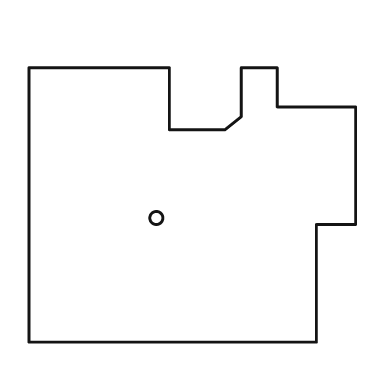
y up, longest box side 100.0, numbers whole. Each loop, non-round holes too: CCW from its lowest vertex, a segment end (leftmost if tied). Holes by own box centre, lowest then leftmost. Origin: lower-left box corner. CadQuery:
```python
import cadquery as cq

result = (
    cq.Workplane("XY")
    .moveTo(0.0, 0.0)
    .lineTo(88.0, 0.0)
    .lineTo(88.0, 36.0)
    .lineTo(100.0, 36.0)
    .lineTo(100.0, 72.0)
    .lineTo(76.0, 72.0)
    .lineTo(76.0, 84.0)
    .lineTo(65.0, 84.0)
    .lineTo(65.0, 69.0)
    .lineTo(60.0, 65.0)
    .lineTo(43.0, 65.0)
    .lineTo(43.0, 84.0)
    .lineTo(0.0, 84.0)
    .close()
    .moveTo(39.0, 38.0)
    .circle(2.0)
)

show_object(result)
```